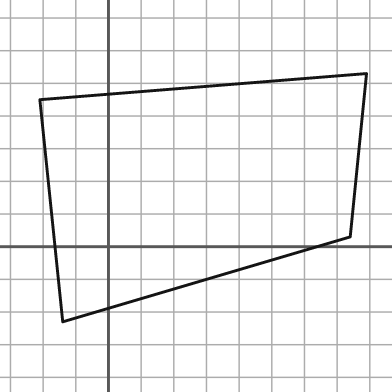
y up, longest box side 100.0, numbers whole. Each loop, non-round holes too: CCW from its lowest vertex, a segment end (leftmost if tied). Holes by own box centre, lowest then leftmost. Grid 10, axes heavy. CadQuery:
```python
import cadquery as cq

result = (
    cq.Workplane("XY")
    .moveTo(-14.0, -23.0)
    .lineTo(74.0, 3.0)
    .lineTo(79.0, 53.0)
    .lineTo(-21.0, 45.0)
    .close()
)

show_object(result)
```